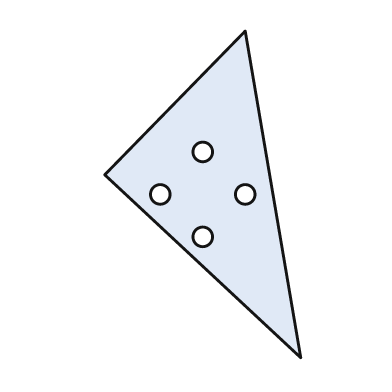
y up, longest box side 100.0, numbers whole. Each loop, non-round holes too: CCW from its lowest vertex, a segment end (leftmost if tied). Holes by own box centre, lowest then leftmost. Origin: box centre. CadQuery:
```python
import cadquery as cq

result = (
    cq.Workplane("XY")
    .moveTo(30.0, -50.0)
    .lineTo(13.0, 50.0)
    .lineTo(-30.0, 6.0)
    .close()
    .moveTo(0.0, -13.0)
    .circle(3.0)
    .moveTo(-13.0, 0.0)
    .circle(3.0)
    .moveTo(13.0, 0.0)
    .circle(3.0)
    .moveTo(0.0, 13.0)
    .circle(3.0)
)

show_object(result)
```